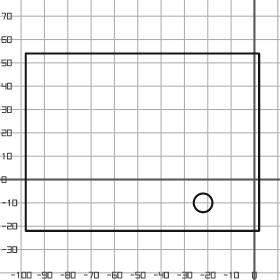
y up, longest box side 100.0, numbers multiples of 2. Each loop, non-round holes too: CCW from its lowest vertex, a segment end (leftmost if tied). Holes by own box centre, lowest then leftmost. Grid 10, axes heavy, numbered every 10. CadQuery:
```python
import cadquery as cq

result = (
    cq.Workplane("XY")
    .moveTo(-98.0, -22.0)
    .lineTo(2.0, -22.0)
    .lineTo(2.0, 54.0)
    .lineTo(-98.0, 54.0)
    .close()
    .moveTo(-22.0, -10.0)
    .circle(4.0)
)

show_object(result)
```